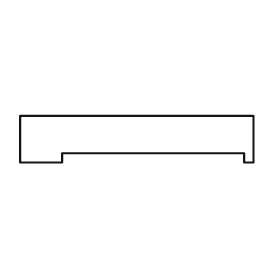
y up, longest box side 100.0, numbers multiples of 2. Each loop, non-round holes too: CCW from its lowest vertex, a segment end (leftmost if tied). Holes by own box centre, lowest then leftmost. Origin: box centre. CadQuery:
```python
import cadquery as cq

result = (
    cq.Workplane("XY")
    .moveTo(-50.0, -10.0)
    .lineTo(-32.0, -10.0)
    .lineTo(-32.0, -6.0)
    .lineTo(46.0, -6.0)
    .lineTo(46.0, -10.0)
    .lineTo(50.0, -10.0)
    .lineTo(50.0, 10.0)
    .lineTo(-50.0, 10.0)
    .close()
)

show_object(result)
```